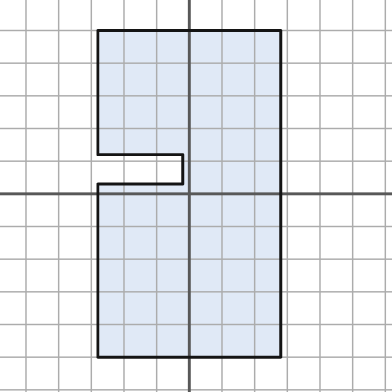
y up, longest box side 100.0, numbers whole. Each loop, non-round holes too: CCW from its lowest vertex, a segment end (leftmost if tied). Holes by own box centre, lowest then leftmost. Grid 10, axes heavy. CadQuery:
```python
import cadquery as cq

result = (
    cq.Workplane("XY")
    .moveTo(-28.0, -50.0)
    .lineTo(28.0, -50.0)
    .lineTo(28.0, 50.0)
    .lineTo(-28.0, 50.0)
    .lineTo(-28.0, 12.0)
    .lineTo(-2.0, 12.0)
    .lineTo(-2.0, 3.0)
    .lineTo(-28.0, 3.0)
    .close()
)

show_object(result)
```